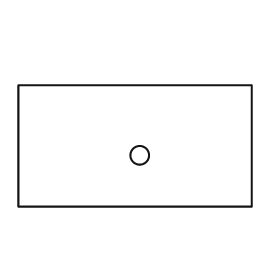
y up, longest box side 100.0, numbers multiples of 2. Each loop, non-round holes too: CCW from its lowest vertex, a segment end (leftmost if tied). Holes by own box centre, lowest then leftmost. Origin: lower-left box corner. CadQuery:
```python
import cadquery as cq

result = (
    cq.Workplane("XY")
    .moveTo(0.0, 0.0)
    .lineTo(100.0, 0.0)
    .lineTo(100.0, 52.0)
    .lineTo(0.0, 52.0)
    .close()
    .moveTo(52.0, 22.0)
    .circle(4.0)
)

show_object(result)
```